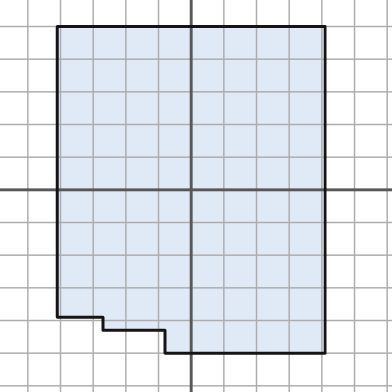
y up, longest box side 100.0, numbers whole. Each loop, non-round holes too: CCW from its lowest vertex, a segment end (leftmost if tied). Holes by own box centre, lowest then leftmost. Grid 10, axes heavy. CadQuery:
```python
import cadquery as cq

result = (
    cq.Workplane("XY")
    .moveTo(-8.0, -50.0)
    .lineTo(41.0, -50.0)
    .lineTo(41.0, 50.0)
    .lineTo(-41.0, 50.0)
    .lineTo(-41.0, -39.0)
    .lineTo(-27.0, -39.0)
    .lineTo(-27.0, -43.0)
    .lineTo(-8.0, -43.0)
    .close()
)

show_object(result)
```